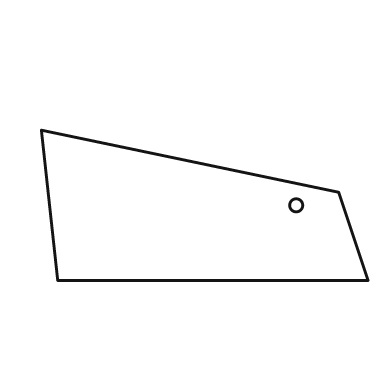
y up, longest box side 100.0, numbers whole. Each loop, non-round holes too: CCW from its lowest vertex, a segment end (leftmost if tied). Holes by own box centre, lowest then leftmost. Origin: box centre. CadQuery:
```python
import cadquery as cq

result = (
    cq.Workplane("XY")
    .moveTo(-45.0, -23.0)
    .lineTo(50.0, -23.0)
    .lineTo(41.0, 4.0)
    .lineTo(-50.0, 23.0)
    .close()
    .moveTo(28.0, 0.0)
    .circle(2.0)
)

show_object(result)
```